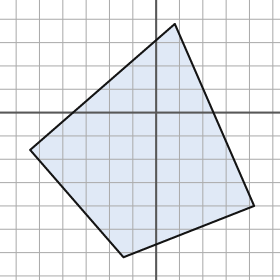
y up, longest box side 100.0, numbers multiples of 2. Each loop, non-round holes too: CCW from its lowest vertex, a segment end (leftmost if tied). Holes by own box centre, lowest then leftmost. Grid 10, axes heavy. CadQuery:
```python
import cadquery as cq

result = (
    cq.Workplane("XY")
    .moveTo(-14.0, -62.0)
    .lineTo(42.0, -40.0)
    .lineTo(8.0, 38.0)
    .lineTo(-54.0, -16.0)
    .close()
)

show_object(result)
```